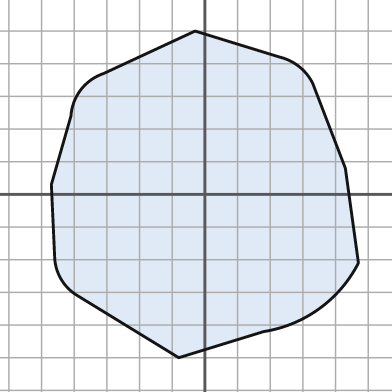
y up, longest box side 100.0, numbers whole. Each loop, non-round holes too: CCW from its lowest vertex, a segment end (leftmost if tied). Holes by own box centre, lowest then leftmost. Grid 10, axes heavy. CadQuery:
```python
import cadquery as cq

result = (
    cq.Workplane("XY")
    .moveTo(-8.0, -50.0)
    .lineTo(18.0, -42.0)
    .threePointArc((35.0, -35.0), (47.0, -21.0))
    .lineTo(43.0, 8.0)
    .lineTo(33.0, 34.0)
    .threePointArc((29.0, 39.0), (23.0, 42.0))
    .lineTo(-3.0, 50.0)
    .lineTo(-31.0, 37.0)
    .threePointArc((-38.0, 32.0), (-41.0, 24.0))
    .lineTo(-47.0, 3.0)
    .lineTo(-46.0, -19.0)
    .threePointArc((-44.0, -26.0), (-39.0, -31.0))
    .close()
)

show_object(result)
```